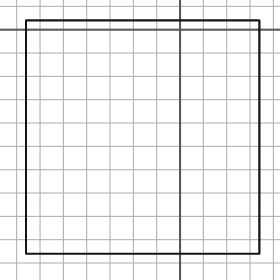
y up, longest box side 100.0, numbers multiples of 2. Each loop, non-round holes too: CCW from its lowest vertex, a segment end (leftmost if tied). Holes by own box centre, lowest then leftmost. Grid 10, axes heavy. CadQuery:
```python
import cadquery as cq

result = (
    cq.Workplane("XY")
    .moveTo(-66.0, -96.0)
    .lineTo(34.0, -96.0)
    .lineTo(34.0, 4.0)
    .lineTo(-66.0, 4.0)
    .close()
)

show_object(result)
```